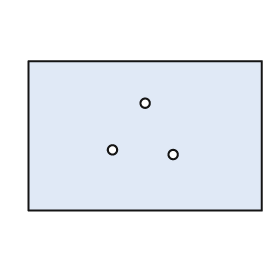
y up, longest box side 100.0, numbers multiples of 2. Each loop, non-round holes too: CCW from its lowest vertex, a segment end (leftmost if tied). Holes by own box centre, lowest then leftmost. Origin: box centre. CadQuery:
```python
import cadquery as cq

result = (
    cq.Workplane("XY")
    .moveTo(-50.0, -32.0)
    .lineTo(50.0, -32.0)
    .lineTo(50.0, 32.0)
    .lineTo(-50.0, 32.0)
    .close()
    .moveTo(12.0, -8.0)
    .circle(2.0)
    .moveTo(-14.0, -6.0)
    .circle(2.0)
    .moveTo(0.0, 14.0)
    .circle(2.0)
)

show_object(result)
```